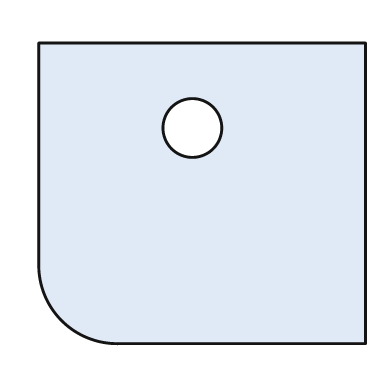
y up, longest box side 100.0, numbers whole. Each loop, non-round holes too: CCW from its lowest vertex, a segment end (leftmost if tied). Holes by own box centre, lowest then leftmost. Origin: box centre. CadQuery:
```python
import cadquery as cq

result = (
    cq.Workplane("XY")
    .moveTo(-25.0, -46.0)
    .lineTo(50.0, -46.0)
    .lineTo(50.0, 46.0)
    .lineTo(-50.0, 46.0)
    .lineTo(-50.0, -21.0)
    .threePointArc((-43.0, -39.0), (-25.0, -46.0))
    .close()
    .moveTo(-3.0, 20.0)
    .circle(9.0)
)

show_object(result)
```